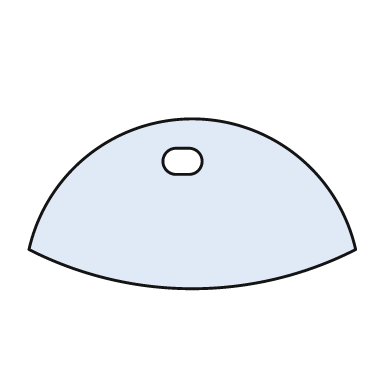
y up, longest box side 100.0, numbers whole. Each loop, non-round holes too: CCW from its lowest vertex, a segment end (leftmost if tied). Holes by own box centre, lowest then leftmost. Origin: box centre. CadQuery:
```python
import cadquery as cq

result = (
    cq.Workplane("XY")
    .moveTo(-50.0, -14.0)
    .threePointArc((0.0, -26.0), (50.0, -14.0))
    .threePointArc((0.0, 26.0), (-50.0, -14.0))
    .close()
    .moveTo(-5.0, 9.0)
    .lineTo(-1.0, 9.0)
    .threePointArc((3.0, 13.0), (-1.0, 17.0))
    .lineTo(-5.0, 17.0)
    .threePointArc((-9.0, 13.0), (-5.0, 9.0))
    .close()
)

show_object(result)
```